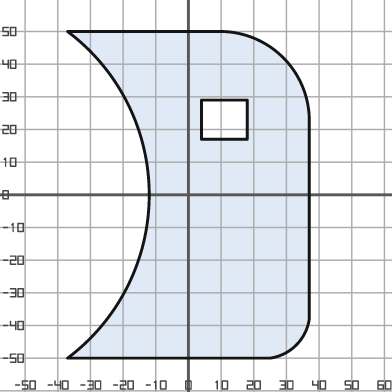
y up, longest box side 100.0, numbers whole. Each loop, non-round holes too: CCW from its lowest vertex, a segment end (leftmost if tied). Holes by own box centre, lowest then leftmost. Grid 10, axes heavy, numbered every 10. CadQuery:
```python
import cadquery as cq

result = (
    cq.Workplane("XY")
    .moveTo(-37.0, -50.0)
    .lineTo(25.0, -50.0)
    .threePointArc((33.0, -46.0), (37.0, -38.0))
    .lineTo(37.0, 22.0)
    .threePointArc((29.0, 42.0), (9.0, 50.0))
    .lineTo(-37.0, 50.0)
    .threePointArc((-12.0, 0.0), (-37.0, -50.0))
    .close()
    .moveTo(4.0, 17.0)
    .lineTo(18.0, 17.0)
    .lineTo(18.0, 29.0)
    .lineTo(4.0, 29.0)
    .close()
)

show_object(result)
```